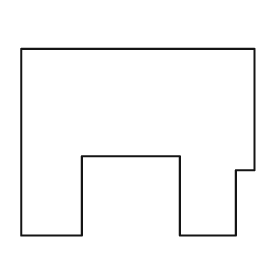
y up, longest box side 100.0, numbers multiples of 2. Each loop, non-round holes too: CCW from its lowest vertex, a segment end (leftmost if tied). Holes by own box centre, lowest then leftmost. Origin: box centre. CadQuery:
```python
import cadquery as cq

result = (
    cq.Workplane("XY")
    .moveTo(-50.0, -40.0)
    .lineTo(-24.0, -40.0)
    .lineTo(-24.0, -6.0)
    .lineTo(18.0, -6.0)
    .lineTo(18.0, -40.0)
    .lineTo(42.0, -40.0)
    .lineTo(42.0, -12.0)
    .lineTo(50.0, -12.0)
    .lineTo(50.0, 40.0)
    .lineTo(-50.0, 40.0)
    .close()
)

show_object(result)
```